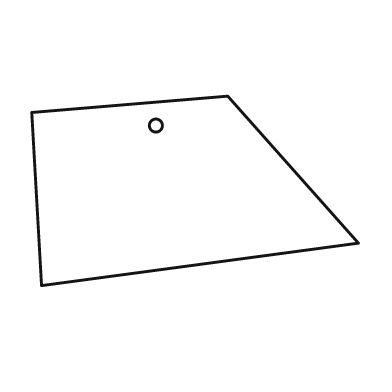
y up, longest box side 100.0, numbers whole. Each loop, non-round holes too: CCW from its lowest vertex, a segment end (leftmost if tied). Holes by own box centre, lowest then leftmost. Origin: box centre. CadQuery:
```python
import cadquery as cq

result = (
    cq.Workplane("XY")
    .moveTo(-47.0, -29.0)
    .lineTo(50.0, -16.0)
    .lineTo(10.0, 29.0)
    .lineTo(-50.0, 24.0)
    .close()
    .moveTo(-12.0, 20.0)
    .circle(2.0)
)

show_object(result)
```